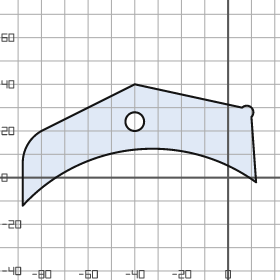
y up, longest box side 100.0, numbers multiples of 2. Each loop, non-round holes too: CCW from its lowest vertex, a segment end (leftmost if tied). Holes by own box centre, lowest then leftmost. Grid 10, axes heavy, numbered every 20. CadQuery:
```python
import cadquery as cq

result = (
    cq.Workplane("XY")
    .moveTo(-88.0, -12.0)
    .threePointArc((-40.0, 12.0), (12.0, -2.0))
    .lineTo(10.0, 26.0)
    .threePointArc((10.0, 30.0), (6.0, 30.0))
    .lineTo(-40.0, 40.0)
    .lineTo(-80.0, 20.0)
    .threePointArc((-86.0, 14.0), (-88.0, 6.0))
    .close()
    .moveTo(-40.0, 24.0)
    .circle(4.0)
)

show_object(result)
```